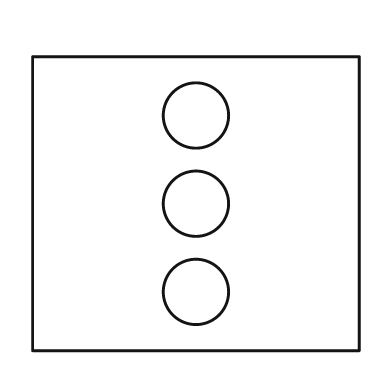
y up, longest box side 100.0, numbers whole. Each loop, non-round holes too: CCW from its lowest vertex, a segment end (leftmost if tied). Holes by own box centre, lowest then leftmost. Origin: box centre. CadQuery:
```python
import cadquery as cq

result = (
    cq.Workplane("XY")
    .moveTo(-50.0, -45.0)
    .lineTo(50.0, -45.0)
    .lineTo(50.0, 45.0)
    .lineTo(-50.0, 45.0)
    .close()
    .moveTo(0.0, -27.0)
    .circle(10.0)
    .moveTo(0.0, 0.0)
    .circle(10.0)
    .moveTo(0.0, 27.0)
    .circle(10.0)
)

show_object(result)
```